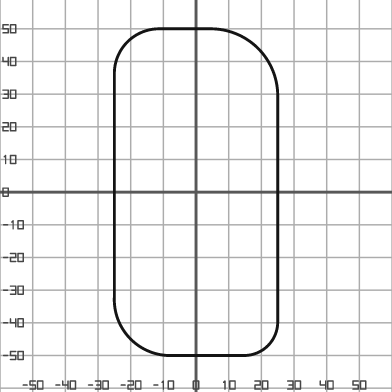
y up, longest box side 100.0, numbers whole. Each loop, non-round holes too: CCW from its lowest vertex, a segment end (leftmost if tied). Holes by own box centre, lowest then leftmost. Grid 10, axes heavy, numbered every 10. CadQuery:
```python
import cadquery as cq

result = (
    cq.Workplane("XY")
    .moveTo(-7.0, -50.0)
    .lineTo(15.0, -50.0)
    .threePointArc((22.0, -47.0), (25.0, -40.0))
    .lineTo(25.0, 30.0)
    .threePointArc((19.0, 44.0), (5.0, 50.0))
    .lineTo(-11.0, 50.0)
    .threePointArc((-21.0, 46.0), (-25.0, 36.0))
    .lineTo(-25.0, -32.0)
    .threePointArc((-20.0, -45.0), (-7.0, -50.0))
    .close()
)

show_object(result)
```